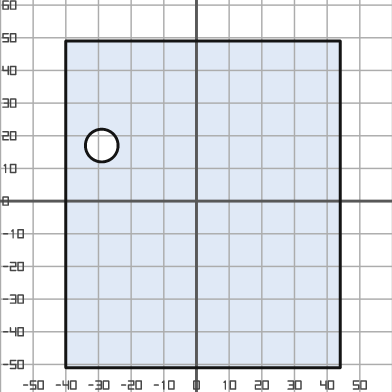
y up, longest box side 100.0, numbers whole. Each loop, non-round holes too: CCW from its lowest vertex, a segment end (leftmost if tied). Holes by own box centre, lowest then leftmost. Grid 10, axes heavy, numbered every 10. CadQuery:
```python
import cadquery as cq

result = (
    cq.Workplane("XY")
    .moveTo(-40.0, -51.0)
    .lineTo(44.0, -51.0)
    .lineTo(44.0, 49.0)
    .lineTo(-40.0, 49.0)
    .close()
    .moveTo(-29.0, 17.0)
    .circle(5.0)
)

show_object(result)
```